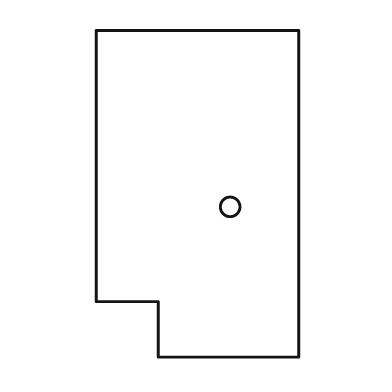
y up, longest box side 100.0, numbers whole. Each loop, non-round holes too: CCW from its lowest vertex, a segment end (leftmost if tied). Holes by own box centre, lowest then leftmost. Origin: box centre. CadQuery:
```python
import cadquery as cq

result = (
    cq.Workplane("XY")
    .moveTo(-12.0, -50.0)
    .lineTo(31.0, -50.0)
    .lineTo(31.0, 50.0)
    .lineTo(-31.0, 50.0)
    .lineTo(-31.0, -33.0)
    .lineTo(-12.0, -33.0)
    .close()
    .moveTo(10.0, -4.0)
    .circle(3.0)
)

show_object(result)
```